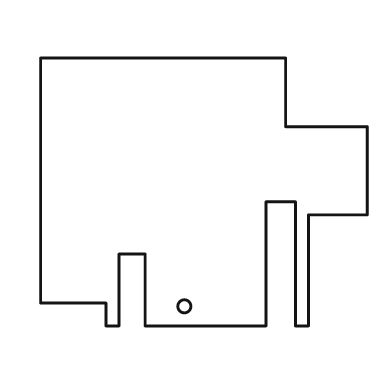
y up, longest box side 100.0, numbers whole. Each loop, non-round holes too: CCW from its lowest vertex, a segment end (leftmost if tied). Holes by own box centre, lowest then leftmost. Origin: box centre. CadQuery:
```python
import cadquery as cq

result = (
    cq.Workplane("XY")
    .moveTo(-30.0, -41.0)
    .lineTo(-26.0, -41.0)
    .lineTo(-26.0, -19.0)
    .lineTo(-18.0, -19.0)
    .lineTo(-18.0, -41.0)
    .lineTo(19.0, -41.0)
    .lineTo(19.0, -3.0)
    .lineTo(28.0, -3.0)
    .lineTo(28.0, -41.0)
    .lineTo(32.0, -41.0)
    .lineTo(32.0, -7.0)
    .lineTo(50.0, -7.0)
    .lineTo(50.0, 20.0)
    .lineTo(25.0, 20.0)
    .lineTo(25.0, 41.0)
    .lineTo(-50.0, 41.0)
    .lineTo(-50.0, -34.0)
    .lineTo(-30.0, -34.0)
    .close()
    .moveTo(-6.0, -35.0)
    .circle(2.0)
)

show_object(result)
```